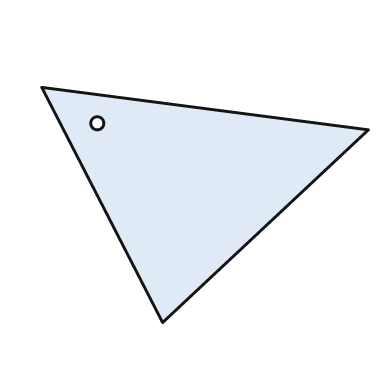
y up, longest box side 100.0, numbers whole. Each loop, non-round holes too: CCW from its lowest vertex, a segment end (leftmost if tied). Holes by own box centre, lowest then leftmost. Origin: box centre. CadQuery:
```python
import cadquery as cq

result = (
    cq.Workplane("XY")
    .moveTo(-13.0, -36.0)
    .lineTo(50.0, 23.0)
    .lineTo(-50.0, 36.0)
    .close()
    .moveTo(-33.0, 25.0)
    .circle(2.0)
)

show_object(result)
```